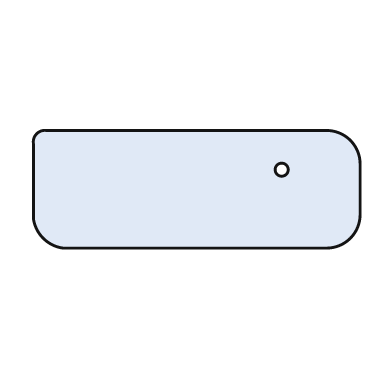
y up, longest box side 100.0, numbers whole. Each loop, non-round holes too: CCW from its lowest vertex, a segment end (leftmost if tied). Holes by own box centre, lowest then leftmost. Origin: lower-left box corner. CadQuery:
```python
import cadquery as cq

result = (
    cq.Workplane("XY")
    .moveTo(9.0, 0.0)
    .lineTo(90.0, 0.0)
    .threePointArc((97.0, 3.0), (100.0, 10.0))
    .lineTo(100.0, 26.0)
    .threePointArc((97.0, 33.0), (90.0, 36.0))
    .lineTo(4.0, 36.0)
    .threePointArc((1.0, 35.0), (0.0, 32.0))
    .lineTo(0.0, 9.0)
    .threePointArc((3.0, 3.0), (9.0, 0.0))
    .close()
    .moveTo(76.0, 24.0)
    .circle(2.0)
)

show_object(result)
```